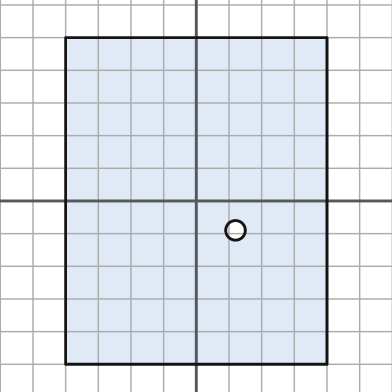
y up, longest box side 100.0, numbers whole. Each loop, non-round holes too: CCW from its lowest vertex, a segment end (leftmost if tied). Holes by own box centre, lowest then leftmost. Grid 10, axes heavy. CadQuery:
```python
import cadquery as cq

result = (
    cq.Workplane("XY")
    .moveTo(-40.0, -50.0)
    .lineTo(40.0, -50.0)
    .lineTo(40.0, 50.0)
    .lineTo(-40.0, 50.0)
    .close()
    .moveTo(12.0, -9.0)
    .circle(3.0)
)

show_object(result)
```